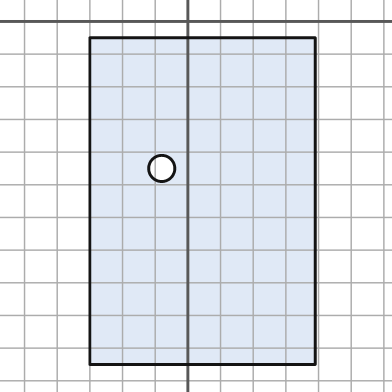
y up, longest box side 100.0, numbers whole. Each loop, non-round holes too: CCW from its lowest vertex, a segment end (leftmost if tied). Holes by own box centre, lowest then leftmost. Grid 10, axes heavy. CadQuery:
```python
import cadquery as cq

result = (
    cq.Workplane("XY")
    .moveTo(-30.0, -105.0)
    .lineTo(39.0, -105.0)
    .lineTo(39.0, -5.0)
    .lineTo(-30.0, -5.0)
    .close()
    .moveTo(-8.0, -45.0)
    .circle(4.0)
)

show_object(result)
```